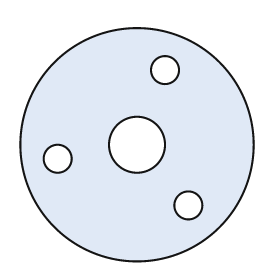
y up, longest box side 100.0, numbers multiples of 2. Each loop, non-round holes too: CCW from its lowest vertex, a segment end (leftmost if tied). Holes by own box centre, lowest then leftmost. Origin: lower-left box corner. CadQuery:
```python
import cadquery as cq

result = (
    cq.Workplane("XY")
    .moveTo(50.0, 50.0)
    .circle(50.0)
    .moveTo(72.0, 24.0)
    .circle(6.0)
    .moveTo(16.0, 44.0)
    .circle(6.0)
    .moveTo(50.0, 50.0)
    .circle(12.0)
    .moveTo(62.0, 82.0)
    .circle(6.0)
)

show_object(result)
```